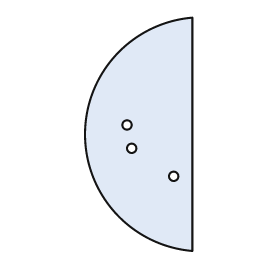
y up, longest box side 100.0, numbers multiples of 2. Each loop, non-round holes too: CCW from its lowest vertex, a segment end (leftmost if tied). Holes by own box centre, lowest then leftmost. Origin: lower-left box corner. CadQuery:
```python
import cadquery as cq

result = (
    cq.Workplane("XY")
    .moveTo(46.0, 0.0)
    .lineTo(46.0, 100.0)
    .threePointArc((0.0, 50.0), (46.0, 0.0))
    .close()
    .moveTo(38.0, 32.0)
    .circle(2.0)
    .moveTo(20.0, 44.0)
    .circle(2.0)
    .moveTo(18.0, 54.0)
    .circle(2.0)
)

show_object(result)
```